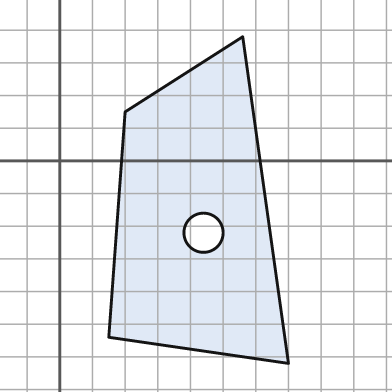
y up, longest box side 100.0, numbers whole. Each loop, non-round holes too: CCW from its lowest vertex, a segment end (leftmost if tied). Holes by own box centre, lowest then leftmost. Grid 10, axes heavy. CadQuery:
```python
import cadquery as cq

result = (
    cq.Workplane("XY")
    .moveTo(70.0, -62.0)
    .lineTo(56.0, 38.0)
    .lineTo(20.0, 15.0)
    .lineTo(15.0, -54.0)
    .close()
    .moveTo(44.0, -22.0)
    .circle(6.0)
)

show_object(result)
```